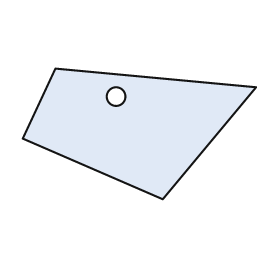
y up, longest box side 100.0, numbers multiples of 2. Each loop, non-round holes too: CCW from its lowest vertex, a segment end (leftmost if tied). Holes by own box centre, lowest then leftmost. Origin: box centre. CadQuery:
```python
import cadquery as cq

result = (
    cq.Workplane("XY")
    .moveTo(10.0, -28.0)
    .lineTo(50.0, 20.0)
    .lineTo(-36.0, 28.0)
    .lineTo(-50.0, -2.0)
    .close()
    .moveTo(-10.0, 16.0)
    .circle(4.0)
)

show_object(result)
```